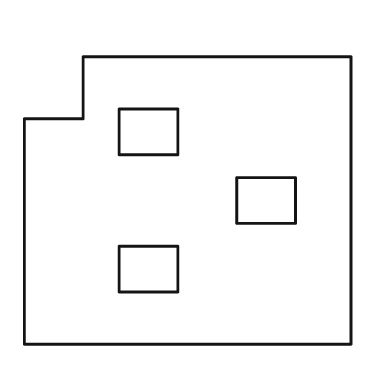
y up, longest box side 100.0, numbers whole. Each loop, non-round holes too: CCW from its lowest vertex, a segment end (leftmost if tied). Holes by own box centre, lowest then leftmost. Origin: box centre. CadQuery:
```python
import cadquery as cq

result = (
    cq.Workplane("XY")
    .moveTo(-50.0, -44.0)
    .lineTo(50.0, -44.0)
    .lineTo(50.0, 44.0)
    .lineTo(-32.0, 44.0)
    .lineTo(-32.0, 25.0)
    .lineTo(-50.0, 25.0)
    .close()
    .moveTo(-21.0, -28.0)
    .lineTo(-3.0, -28.0)
    .lineTo(-3.0, -14.0)
    .lineTo(-21.0, -14.0)
    .close()
    .moveTo(15.0, -7.0)
    .lineTo(33.0, -7.0)
    .lineTo(33.0, 7.0)
    .lineTo(15.0, 7.0)
    .close()
    .moveTo(-21.0, 14.0)
    .lineTo(-3.0, 14.0)
    .lineTo(-3.0, 28.0)
    .lineTo(-21.0, 28.0)
    .close()
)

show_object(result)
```